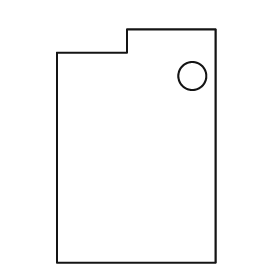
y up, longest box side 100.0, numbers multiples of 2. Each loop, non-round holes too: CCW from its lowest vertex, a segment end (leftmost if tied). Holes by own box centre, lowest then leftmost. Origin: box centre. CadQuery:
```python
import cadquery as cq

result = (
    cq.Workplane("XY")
    .moveTo(-34.0, -50.0)
    .lineTo(34.0, -50.0)
    .lineTo(34.0, 50.0)
    .lineTo(-4.0, 50.0)
    .lineTo(-4.0, 40.0)
    .lineTo(-34.0, 40.0)
    .close()
    .moveTo(24.0, 30.0)
    .circle(6.0)
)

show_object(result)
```